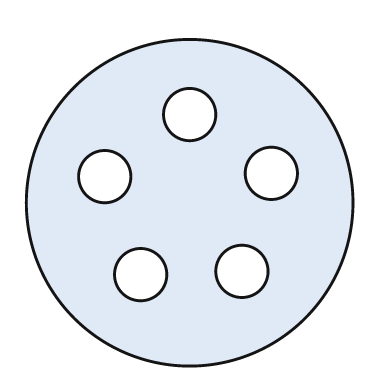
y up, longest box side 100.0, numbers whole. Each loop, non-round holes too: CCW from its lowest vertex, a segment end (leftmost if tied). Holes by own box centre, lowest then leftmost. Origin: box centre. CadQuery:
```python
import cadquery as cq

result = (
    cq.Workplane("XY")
    .moveTo(0.0, 0.0)
    .circle(50.0)
    .moveTo(-15.0, -22.0)
    .circle(8.0)
    .moveTo(16.0, -21.0)
    .circle(8.0)
    .moveTo(-26.0, 8.0)
    .circle(8.0)
    .moveTo(25.0, 9.0)
    .circle(8.0)
    .moveTo(0.0, 27.0)
    .circle(8.0)
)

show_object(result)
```